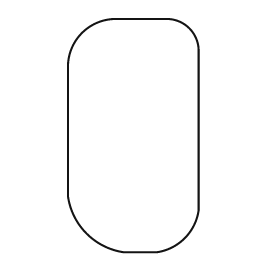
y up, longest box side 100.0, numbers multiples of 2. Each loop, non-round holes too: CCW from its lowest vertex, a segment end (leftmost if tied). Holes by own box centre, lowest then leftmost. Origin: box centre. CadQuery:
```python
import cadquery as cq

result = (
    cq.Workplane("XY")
    .moveTo(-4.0, -50.0)
    .lineTo(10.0, -50.0)
    .threePointArc((22.0, -44.0), (28.0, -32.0))
    .lineTo(28.0, 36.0)
    .threePointArc((24.0, 46.0), (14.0, 50.0))
    .lineTo(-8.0, 50.0)
    .threePointArc((-22.0, 44.0), (-28.0, 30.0))
    .lineTo(-28.0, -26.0)
    .threePointArc((-20.0, -42.0), (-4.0, -50.0))
    .close()
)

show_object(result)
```